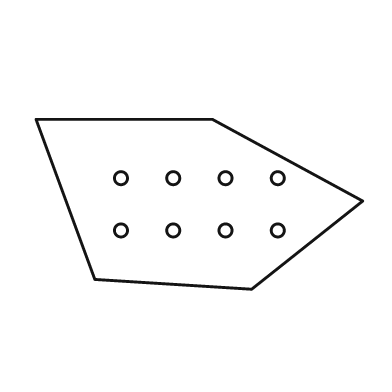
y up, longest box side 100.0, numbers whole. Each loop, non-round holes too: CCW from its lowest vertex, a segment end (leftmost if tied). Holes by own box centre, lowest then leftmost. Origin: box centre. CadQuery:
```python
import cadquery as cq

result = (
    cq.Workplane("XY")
    .moveTo(16.0, -26.0)
    .lineTo(50.0, 1.0)
    .lineTo(4.0, 26.0)
    .lineTo(-50.0, 26.0)
    .lineTo(-32.0, -23.0)
    .close()
    .moveTo(-24.0, -8.0)
    .circle(2.0)
    .moveTo(-8.0, -8.0)
    .circle(2.0)
    .moveTo(8.0, -8.0)
    .circle(2.0)
    .moveTo(24.0, -8.0)
    .circle(2.0)
    .moveTo(-24.0, 8.0)
    .circle(2.0)
    .moveTo(-8.0, 8.0)
    .circle(2.0)
    .moveTo(8.0, 8.0)
    .circle(2.0)
    .moveTo(24.0, 8.0)
    .circle(2.0)
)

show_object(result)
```